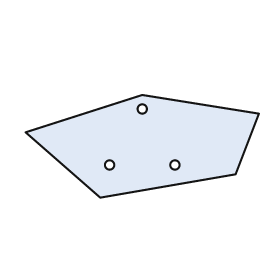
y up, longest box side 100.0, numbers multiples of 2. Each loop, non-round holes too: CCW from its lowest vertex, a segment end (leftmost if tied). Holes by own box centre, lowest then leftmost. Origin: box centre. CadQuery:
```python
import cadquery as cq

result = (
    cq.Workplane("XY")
    .moveTo(-18.0, -22.0)
    .lineTo(40.0, -12.0)
    .lineTo(50.0, 14.0)
    .lineTo(0.0, 22.0)
    .lineTo(-50.0, 6.0)
    .close()
    .moveTo(-14.0, -8.0)
    .circle(2.0)
    .moveTo(14.0, -8.0)
    .circle(2.0)
    .moveTo(0.0, 16.0)
    .circle(2.0)
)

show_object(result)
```